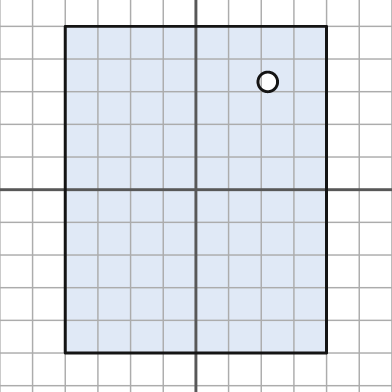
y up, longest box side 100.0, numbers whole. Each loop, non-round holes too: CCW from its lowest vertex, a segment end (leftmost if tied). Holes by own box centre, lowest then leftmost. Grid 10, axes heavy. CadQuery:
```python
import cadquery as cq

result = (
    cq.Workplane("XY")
    .moveTo(-40.0, -50.0)
    .lineTo(40.0, -50.0)
    .lineTo(40.0, 50.0)
    .lineTo(-40.0, 50.0)
    .close()
    .moveTo(22.0, 33.0)
    .circle(3.0)
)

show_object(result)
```